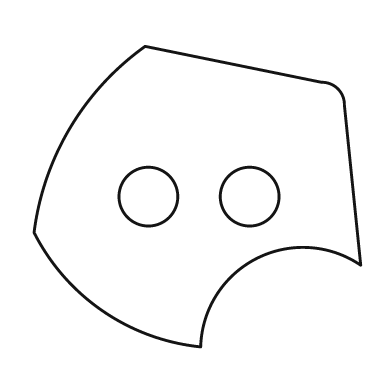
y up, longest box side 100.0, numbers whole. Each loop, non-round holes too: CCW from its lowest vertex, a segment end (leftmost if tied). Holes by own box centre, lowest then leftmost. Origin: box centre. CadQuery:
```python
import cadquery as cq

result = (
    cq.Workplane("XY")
    .moveTo(1.0, -46.0)
    .threePointArc((18.0, -19.0), (50.0, -21.0))
    .lineTo(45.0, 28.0)
    .threePointArc((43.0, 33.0), (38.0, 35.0))
    .lineTo(-16.0, 46.0)
    .threePointArc((-39.0, 21.0), (-50.0, -11.0))
    .threePointArc((-29.0, -35.0), (1.0, -46.0))
    .close()
    .moveTo(-15.0, 0.0)
    .circle(9.0)
    .moveTo(16.0, 0.0)
    .circle(9.0)
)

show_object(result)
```